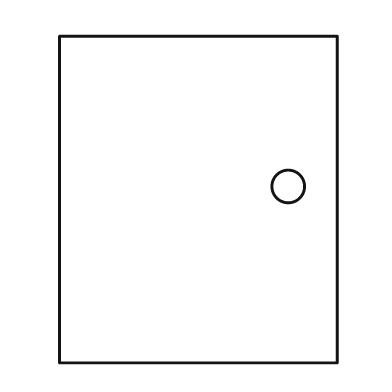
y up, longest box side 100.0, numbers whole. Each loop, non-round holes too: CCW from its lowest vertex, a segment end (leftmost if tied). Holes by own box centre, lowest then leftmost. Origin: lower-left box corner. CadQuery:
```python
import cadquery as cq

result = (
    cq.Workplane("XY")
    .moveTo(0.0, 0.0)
    .lineTo(85.0, 0.0)
    .lineTo(85.0, 100.0)
    .lineTo(0.0, 100.0)
    .close()
    .moveTo(70.0, 54.0)
    .circle(5.0)
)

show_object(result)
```